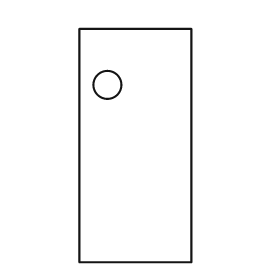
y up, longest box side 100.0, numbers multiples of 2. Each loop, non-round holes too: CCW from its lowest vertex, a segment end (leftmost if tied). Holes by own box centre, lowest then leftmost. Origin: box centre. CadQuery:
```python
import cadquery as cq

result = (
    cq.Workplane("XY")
    .moveTo(-24.0, -50.0)
    .lineTo(24.0, -50.0)
    .lineTo(24.0, 50.0)
    .lineTo(-24.0, 50.0)
    .close()
    .moveTo(-12.0, 26.0)
    .circle(6.0)
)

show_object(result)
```